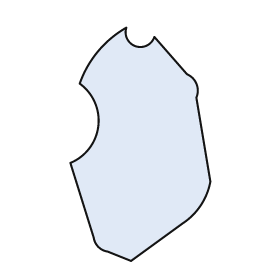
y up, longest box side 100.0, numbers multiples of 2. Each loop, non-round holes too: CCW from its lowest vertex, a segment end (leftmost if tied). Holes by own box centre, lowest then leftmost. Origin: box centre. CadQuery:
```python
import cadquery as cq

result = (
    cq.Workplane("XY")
    .moveTo(-4.0, -50.0)
    .lineTo(18.0, -34.0)
    .threePointArc((26.0, -26.0), (30.0, -16.0))
    .lineTo(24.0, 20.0)
    .threePointArc((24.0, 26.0), (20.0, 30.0))
    .lineTo(6.0, 46.0)
    .threePointArc((-2.0, 42.0), (-6.0, 50.0))
    .threePointArc((-18.0, 40.0), (-26.0, 26.0))
    .threePointArc((-18.0, 8.0), (-30.0, -8.0))
    .lineTo(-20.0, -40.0)
    .threePointArc((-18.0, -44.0), (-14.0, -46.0))
    .close()
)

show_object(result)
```